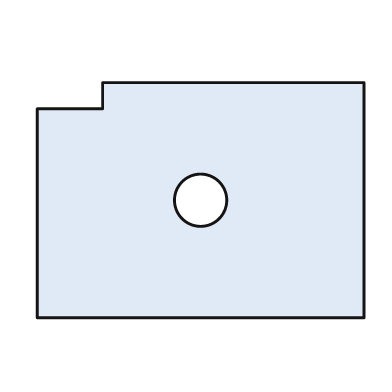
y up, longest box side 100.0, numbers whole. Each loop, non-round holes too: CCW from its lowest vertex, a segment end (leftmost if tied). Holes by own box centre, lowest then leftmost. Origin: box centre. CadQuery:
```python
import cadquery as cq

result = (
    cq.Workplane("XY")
    .moveTo(-50.0, -36.0)
    .lineTo(50.0, -36.0)
    .lineTo(50.0, 36.0)
    .lineTo(-30.0, 36.0)
    .lineTo(-30.0, 28.0)
    .lineTo(-50.0, 28.0)
    .close()
    .moveTo(0.0, 0.0)
    .circle(8.0)
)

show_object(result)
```